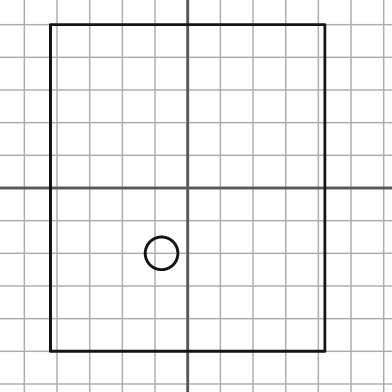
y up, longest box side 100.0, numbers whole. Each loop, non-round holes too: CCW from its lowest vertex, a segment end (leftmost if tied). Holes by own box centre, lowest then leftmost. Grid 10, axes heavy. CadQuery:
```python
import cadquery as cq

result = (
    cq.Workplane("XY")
    .moveTo(-42.0, -50.0)
    .lineTo(42.0, -50.0)
    .lineTo(42.0, 50.0)
    .lineTo(-42.0, 50.0)
    .close()
    .moveTo(-8.0, -20.0)
    .circle(5.0)
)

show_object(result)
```